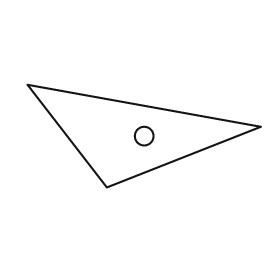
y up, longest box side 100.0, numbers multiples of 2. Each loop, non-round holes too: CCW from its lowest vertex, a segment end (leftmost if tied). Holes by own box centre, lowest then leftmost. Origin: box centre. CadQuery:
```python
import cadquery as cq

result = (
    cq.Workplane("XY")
    .moveTo(-16.0, -22.0)
    .lineTo(50.0, 4.0)
    .lineTo(-50.0, 22.0)
    .close()
    .moveTo(0.0, 0.0)
    .circle(4.0)
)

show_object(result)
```